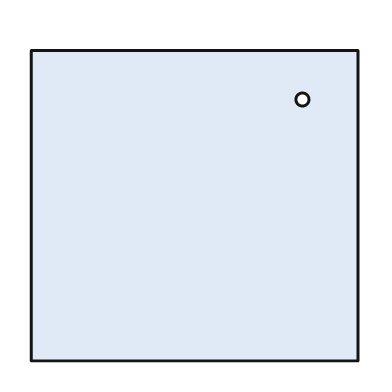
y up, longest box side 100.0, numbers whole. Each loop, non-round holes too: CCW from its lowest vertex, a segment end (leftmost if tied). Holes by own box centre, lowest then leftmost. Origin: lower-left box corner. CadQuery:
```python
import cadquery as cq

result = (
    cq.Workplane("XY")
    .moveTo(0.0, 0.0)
    .lineTo(100.0, 0.0)
    .lineTo(100.0, 95.0)
    .lineTo(0.0, 95.0)
    .close()
    .moveTo(83.0, 80.0)
    .circle(2.0)
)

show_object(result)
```